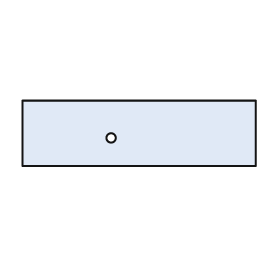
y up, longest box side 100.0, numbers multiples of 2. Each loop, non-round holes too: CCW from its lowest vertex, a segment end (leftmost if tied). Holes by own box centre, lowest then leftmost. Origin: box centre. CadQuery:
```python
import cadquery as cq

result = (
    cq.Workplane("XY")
    .moveTo(-50.0, -14.0)
    .lineTo(50.0, -14.0)
    .lineTo(50.0, 14.0)
    .lineTo(-50.0, 14.0)
    .close()
    .moveTo(-12.0, -2.0)
    .circle(2.0)
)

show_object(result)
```